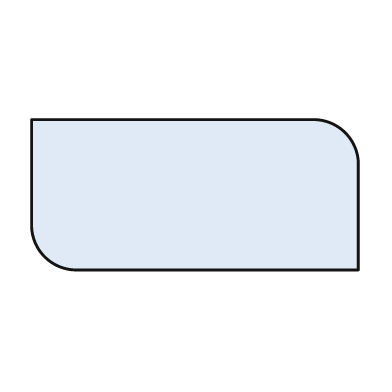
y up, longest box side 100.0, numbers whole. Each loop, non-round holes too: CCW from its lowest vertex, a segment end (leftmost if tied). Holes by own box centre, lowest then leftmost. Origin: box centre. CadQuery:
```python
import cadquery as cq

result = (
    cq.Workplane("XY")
    .moveTo(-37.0, -23.0)
    .lineTo(50.0, -23.0)
    .lineTo(50.0, 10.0)
    .threePointArc((46.0, 19.0), (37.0, 23.0))
    .lineTo(-50.0, 23.0)
    .lineTo(-50.0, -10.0)
    .threePointArc((-46.0, -19.0), (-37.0, -23.0))
    .close()
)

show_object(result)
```